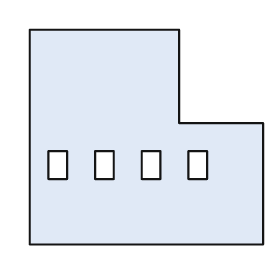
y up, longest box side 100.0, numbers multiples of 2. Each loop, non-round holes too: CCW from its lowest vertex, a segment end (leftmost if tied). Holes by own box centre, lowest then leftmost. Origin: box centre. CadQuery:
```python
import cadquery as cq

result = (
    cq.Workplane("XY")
    .moveTo(-50.0, -46.0)
    .lineTo(50.0, -46.0)
    .lineTo(50.0, 6.0)
    .lineTo(14.0, 6.0)
    .lineTo(14.0, 46.0)
    .lineTo(-50.0, 46.0)
    .close()
    .moveTo(-42.0, -18.0)
    .lineTo(-34.0, -18.0)
    .lineTo(-34.0, -6.0)
    .lineTo(-42.0, -6.0)
    .close()
    .moveTo(-22.0, -18.0)
    .lineTo(-14.0, -18.0)
    .lineTo(-14.0, -6.0)
    .lineTo(-22.0, -6.0)
    .close()
    .moveTo(-2.0, -18.0)
    .lineTo(6.0, -18.0)
    .lineTo(6.0, -6.0)
    .lineTo(-2.0, -6.0)
    .close()
    .moveTo(18.0, -18.0)
    .lineTo(26.0, -18.0)
    .lineTo(26.0, -6.0)
    .lineTo(18.0, -6.0)
    .close()
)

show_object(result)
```